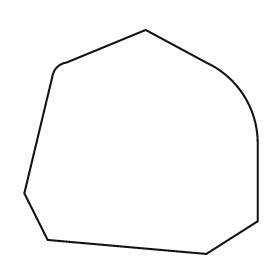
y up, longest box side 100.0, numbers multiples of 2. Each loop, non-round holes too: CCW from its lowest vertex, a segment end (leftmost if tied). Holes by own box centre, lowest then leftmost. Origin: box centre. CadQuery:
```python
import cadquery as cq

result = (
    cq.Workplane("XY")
    .moveTo(28.0, -48.0)
    .lineTo(50.0, -34.0)
    .lineTo(50.0, 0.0)
    .threePointArc((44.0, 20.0), (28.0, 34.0))
    .lineTo(2.0, 48.0)
    .lineTo(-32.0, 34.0)
    .threePointArc((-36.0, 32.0), (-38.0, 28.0))
    .lineTo(-50.0, -22.0)
    .lineTo(-40.0, -42.0)
    .close()
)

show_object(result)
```